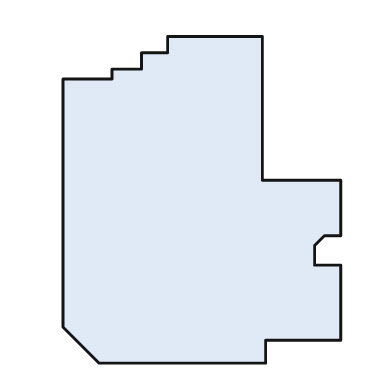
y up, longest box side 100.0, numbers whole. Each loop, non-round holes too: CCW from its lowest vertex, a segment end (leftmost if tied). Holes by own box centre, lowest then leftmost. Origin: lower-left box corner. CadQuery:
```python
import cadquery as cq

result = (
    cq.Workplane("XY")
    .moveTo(11.0, 0.0)
    .lineTo(62.0, 0.0)
    .lineTo(62.0, 7.0)
    .lineTo(85.0, 7.0)
    .lineTo(85.0, 30.0)
    .lineTo(77.0, 30.0)
    .lineTo(77.0, 36.0)
    .lineTo(80.0, 39.0)
    .lineTo(85.0, 39.0)
    .lineTo(85.0, 56.0)
    .lineTo(61.0, 56.0)
    .lineTo(61.0, 100.0)
    .lineTo(32.0, 100.0)
    .lineTo(32.0, 95.0)
    .lineTo(24.0, 95.0)
    .lineTo(24.0, 90.0)
    .lineTo(15.0, 90.0)
    .lineTo(15.0, 87.0)
    .lineTo(0.0, 87.0)
    .lineTo(0.0, 11.0)
    .close()
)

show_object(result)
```